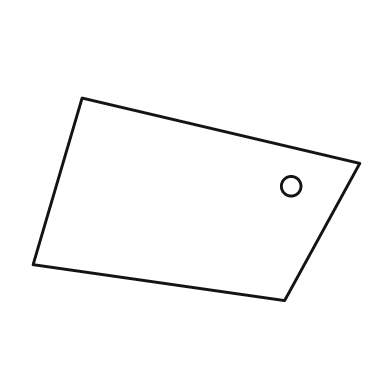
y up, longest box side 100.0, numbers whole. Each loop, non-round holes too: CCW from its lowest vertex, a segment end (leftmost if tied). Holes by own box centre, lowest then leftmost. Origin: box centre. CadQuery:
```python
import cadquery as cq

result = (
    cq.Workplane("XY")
    .moveTo(27.0, -31.0)
    .lineTo(50.0, 11.0)
    .lineTo(-35.0, 31.0)
    .lineTo(-50.0, -20.0)
    .close()
    .moveTo(29.0, 4.0)
    .circle(3.0)
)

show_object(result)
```